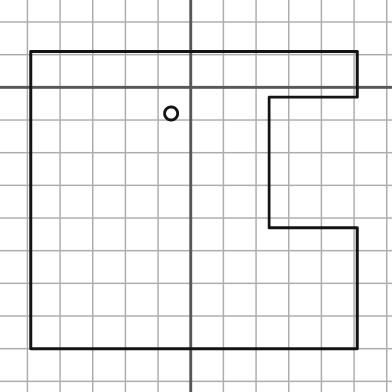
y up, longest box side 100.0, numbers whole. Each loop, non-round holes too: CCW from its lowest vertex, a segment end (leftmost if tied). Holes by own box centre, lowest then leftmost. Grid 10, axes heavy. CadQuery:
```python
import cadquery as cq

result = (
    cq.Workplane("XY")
    .moveTo(-49.0, -80.0)
    .lineTo(51.0, -80.0)
    .lineTo(51.0, -43.0)
    .lineTo(24.0, -43.0)
    .lineTo(24.0, -3.0)
    .lineTo(51.0, -3.0)
    .lineTo(51.0, 11.0)
    .lineTo(-49.0, 11.0)
    .close()
    .moveTo(-6.0, -8.0)
    .circle(2.0)
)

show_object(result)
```